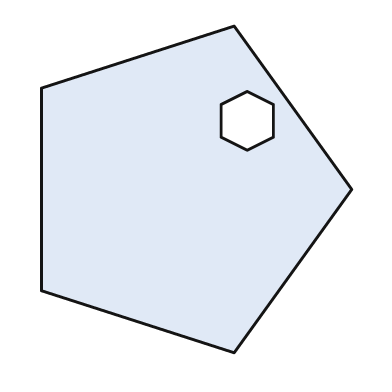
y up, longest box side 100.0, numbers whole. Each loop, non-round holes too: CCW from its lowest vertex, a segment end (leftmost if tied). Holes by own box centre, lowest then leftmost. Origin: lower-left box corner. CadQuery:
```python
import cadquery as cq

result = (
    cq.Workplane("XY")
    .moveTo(59.0, 0.0)
    .lineTo(95.0, 50.0)
    .lineTo(59.0, 100.0)
    .lineTo(0.0, 81.0)
    .lineTo(0.0, 19.0)
    .close()
    .moveTo(63.0, 62.0)
    .lineTo(71.0, 66.0)
    .lineTo(71.0, 76.0)
    .lineTo(63.0, 80.0)
    .lineTo(55.0, 76.0)
    .lineTo(55.0, 66.0)
    .close()
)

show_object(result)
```